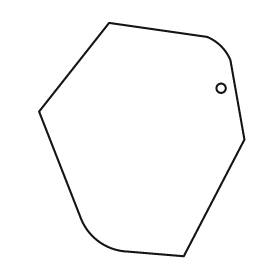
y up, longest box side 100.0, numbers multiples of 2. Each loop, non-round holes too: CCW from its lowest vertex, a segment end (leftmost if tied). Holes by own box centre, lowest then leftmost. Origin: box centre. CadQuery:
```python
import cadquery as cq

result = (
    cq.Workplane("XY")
    .moveTo(18.0, -50.0)
    .lineTo(44.0, 0.0)
    .lineTo(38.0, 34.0)
    .threePointArc((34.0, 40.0), (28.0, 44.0))
    .lineTo(-14.0, 50.0)
    .lineTo(-44.0, 12.0)
    .lineTo(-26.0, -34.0)
    .threePointArc((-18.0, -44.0), (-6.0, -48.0))
    .close()
    .moveTo(34.0, 22.0)
    .circle(2.0)
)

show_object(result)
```